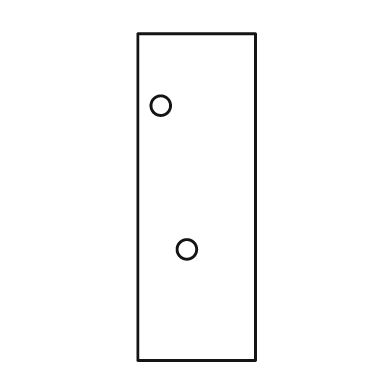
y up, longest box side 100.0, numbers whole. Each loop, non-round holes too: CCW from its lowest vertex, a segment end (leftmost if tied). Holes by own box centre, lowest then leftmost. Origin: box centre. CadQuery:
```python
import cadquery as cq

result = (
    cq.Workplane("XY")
    .moveTo(-18.0, -50.0)
    .lineTo(18.0, -50.0)
    .lineTo(18.0, 50.0)
    .lineTo(-18.0, 50.0)
    .close()
    .moveTo(-3.0, -16.0)
    .circle(3.0)
    .moveTo(-11.0, 28.0)
    .circle(3.0)
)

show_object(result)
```